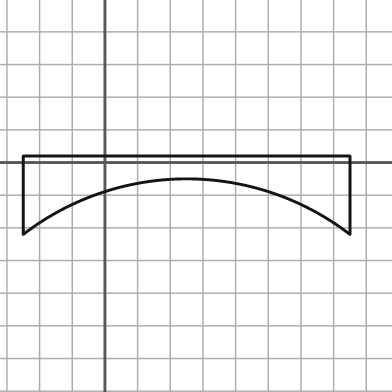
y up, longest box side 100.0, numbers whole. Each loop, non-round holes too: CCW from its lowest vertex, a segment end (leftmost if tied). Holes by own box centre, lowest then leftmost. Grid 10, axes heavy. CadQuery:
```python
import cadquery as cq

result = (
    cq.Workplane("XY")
    .moveTo(-25.0, -22.0)
    .threePointArc((25.0, -5.0), (75.0, -22.0))
    .lineTo(75.0, 2.0)
    .lineTo(-25.0, 2.0)
    .close()
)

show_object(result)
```